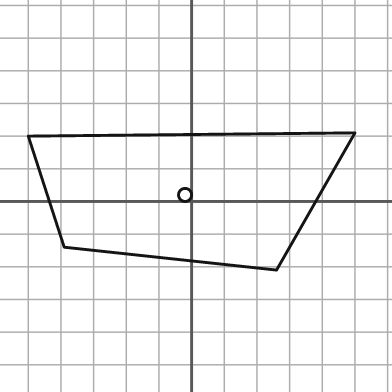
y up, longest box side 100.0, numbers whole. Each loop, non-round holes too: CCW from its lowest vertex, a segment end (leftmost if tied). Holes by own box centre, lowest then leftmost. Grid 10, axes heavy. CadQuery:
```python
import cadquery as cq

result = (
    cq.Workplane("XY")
    .moveTo(26.0, -21.0)
    .lineTo(50.0, 21.0)
    .lineTo(-50.0, 20.0)
    .lineTo(-39.0, -14.0)
    .close()
    .moveTo(-2.0, 2.0)
    .circle(2.0)
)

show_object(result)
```